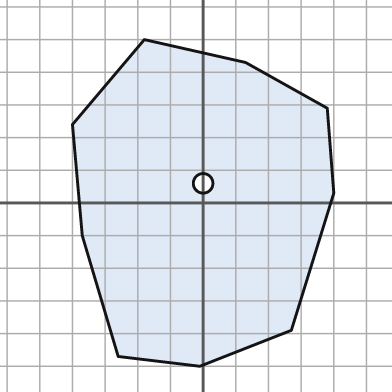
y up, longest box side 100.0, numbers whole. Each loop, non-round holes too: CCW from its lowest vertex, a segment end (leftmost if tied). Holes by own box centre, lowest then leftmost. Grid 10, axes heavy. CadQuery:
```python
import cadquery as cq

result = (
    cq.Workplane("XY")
    .moveTo(-1.0, -50.0)
    .lineTo(27.0, -39.0)
    .lineTo(40.0, 3.0)
    .lineTo(38.0, 29.0)
    .lineTo(13.0, 43.0)
    .lineTo(-18.0, 50.0)
    .lineTo(-40.0, 24.0)
    .lineTo(-37.0, -10.0)
    .lineTo(-26.0, -47.0)
    .close()
    .moveTo(0.0, 6.0)
    .circle(3.0)
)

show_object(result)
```